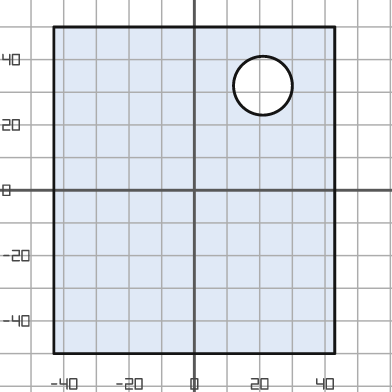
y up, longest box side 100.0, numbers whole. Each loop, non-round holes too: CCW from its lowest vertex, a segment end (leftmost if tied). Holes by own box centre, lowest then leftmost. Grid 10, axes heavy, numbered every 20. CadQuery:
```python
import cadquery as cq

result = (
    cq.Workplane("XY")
    .moveTo(-43.0, -50.0)
    .lineTo(43.0, -50.0)
    .lineTo(43.0, 50.0)
    .lineTo(-43.0, 50.0)
    .close()
    .moveTo(21.0, 32.0)
    .circle(9.0)
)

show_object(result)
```